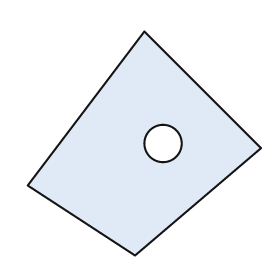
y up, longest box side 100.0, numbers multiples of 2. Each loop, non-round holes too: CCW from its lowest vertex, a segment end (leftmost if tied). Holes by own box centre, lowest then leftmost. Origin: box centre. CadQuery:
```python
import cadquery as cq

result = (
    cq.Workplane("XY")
    .moveTo(-4.0, -48.0)
    .lineTo(50.0, -2.0)
    .lineTo(0.0, 48.0)
    .lineTo(-50.0, -18.0)
    .close()
    .moveTo(8.0, 0.0)
    .circle(8.0)
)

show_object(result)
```